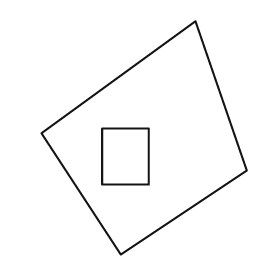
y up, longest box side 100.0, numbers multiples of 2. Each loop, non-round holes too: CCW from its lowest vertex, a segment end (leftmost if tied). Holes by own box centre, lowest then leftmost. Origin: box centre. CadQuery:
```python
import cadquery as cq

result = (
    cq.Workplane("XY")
    .moveTo(-10.0, -50.0)
    .lineTo(44.0, -14.0)
    .lineTo(22.0, 50.0)
    .lineTo(-44.0, 2.0)
    .close()
    .moveTo(-18.0, -20.0)
    .lineTo(2.0, -20.0)
    .lineTo(2.0, 4.0)
    .lineTo(-18.0, 4.0)
    .close()
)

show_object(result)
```